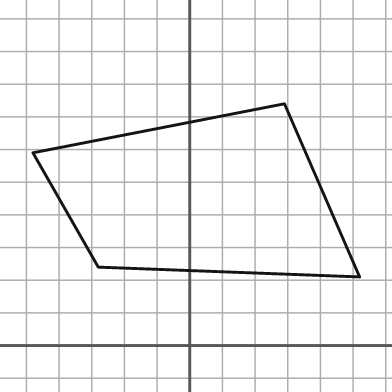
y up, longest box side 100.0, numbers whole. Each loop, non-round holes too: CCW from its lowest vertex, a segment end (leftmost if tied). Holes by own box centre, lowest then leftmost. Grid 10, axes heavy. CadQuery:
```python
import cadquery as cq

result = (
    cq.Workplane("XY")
    .moveTo(52.0, 21.0)
    .lineTo(29.0, 74.0)
    .lineTo(-48.0, 59.0)
    .lineTo(-28.0, 24.0)
    .close()
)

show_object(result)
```